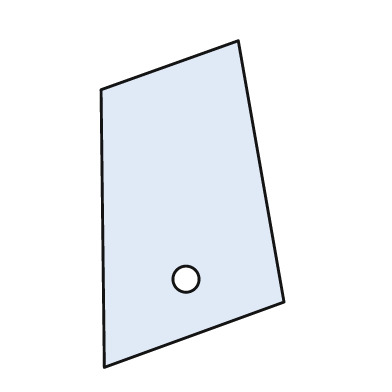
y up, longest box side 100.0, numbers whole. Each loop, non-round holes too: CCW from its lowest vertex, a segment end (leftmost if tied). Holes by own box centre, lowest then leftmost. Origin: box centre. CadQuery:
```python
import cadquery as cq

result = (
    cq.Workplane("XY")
    .moveTo(-27.0, -50.0)
    .lineTo(28.0, -30.0)
    .lineTo(14.0, 50.0)
    .lineTo(-28.0, 35.0)
    .close()
    .moveTo(-2.0, -23.0)
    .circle(4.0)
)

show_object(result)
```